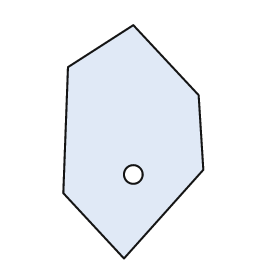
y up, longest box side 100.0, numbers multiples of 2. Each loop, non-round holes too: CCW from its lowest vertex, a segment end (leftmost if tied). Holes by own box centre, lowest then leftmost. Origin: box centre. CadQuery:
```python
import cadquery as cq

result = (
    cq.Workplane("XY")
    .moveTo(-4.0, -50.0)
    .lineTo(30.0, -12.0)
    .lineTo(28.0, 20.0)
    .lineTo(0.0, 50.0)
    .lineTo(-28.0, 32.0)
    .lineTo(-30.0, -22.0)
    .close()
    .moveTo(0.0, -14.0)
    .circle(4.0)
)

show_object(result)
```